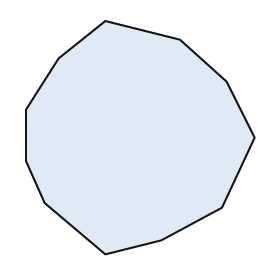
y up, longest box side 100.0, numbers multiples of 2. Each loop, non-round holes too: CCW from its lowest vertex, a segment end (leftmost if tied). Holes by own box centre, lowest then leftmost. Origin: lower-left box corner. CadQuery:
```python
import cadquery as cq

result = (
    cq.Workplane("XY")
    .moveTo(34.0, 0.0)
    .lineTo(58.0, 6.0)
    .lineTo(84.0, 20.0)
    .lineTo(98.0, 50.0)
    .lineTo(86.0, 74.0)
    .lineTo(66.0, 92.0)
    .lineTo(34.0, 100.0)
    .lineTo(14.0, 84.0)
    .lineTo(0.0, 62.0)
    .lineTo(0.0, 40.0)
    .lineTo(8.0, 22.0)
    .close()
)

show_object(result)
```